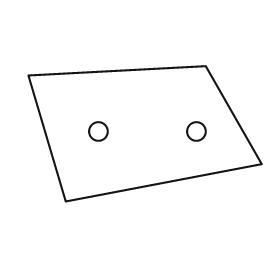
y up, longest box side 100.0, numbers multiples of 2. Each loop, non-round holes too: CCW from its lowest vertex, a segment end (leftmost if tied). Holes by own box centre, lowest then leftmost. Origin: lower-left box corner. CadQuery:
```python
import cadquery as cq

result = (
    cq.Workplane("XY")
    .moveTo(16.0, 0.0)
    .lineTo(100.0, 16.0)
    .lineTo(76.0, 58.0)
    .lineTo(0.0, 54.0)
    .close()
    .moveTo(30.0, 30.0)
    .circle(4.0)
    .moveTo(72.0, 30.0)
    .circle(4.0)
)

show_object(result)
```